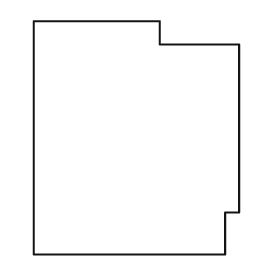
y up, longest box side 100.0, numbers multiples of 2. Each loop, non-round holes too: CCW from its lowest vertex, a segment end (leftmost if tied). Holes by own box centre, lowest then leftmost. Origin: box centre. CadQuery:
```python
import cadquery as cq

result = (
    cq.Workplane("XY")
    .moveTo(-44.0, -50.0)
    .lineTo(38.0, -50.0)
    .lineTo(38.0, -32.0)
    .lineTo(44.0, -32.0)
    .lineTo(44.0, 40.0)
    .lineTo(10.0, 40.0)
    .lineTo(10.0, 50.0)
    .lineTo(-44.0, 50.0)
    .close()
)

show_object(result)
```